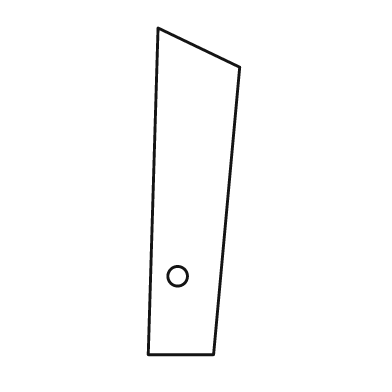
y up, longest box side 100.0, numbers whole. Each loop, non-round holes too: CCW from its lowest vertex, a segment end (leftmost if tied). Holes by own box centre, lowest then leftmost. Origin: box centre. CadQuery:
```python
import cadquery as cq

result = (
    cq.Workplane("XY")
    .moveTo(-14.0, -50.0)
    .lineTo(6.0, -50.0)
    .lineTo(14.0, 38.0)
    .lineTo(-11.0, 50.0)
    .close()
    .moveTo(-5.0, -26.0)
    .circle(3.0)
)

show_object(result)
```